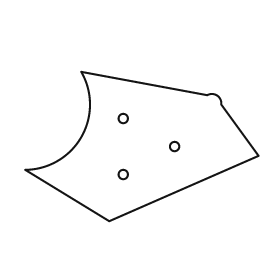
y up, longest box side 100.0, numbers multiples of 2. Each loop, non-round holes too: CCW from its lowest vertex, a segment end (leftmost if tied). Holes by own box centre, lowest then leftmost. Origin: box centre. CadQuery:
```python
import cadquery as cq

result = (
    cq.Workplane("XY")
    .moveTo(-14.0, -32.0)
    .lineTo(50.0, -4.0)
    .lineTo(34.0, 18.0)
    .threePointArc((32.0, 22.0), (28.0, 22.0))
    .lineTo(-26.0, 32.0)
    .threePointArc((-26.0, 4.0), (-50.0, -10.0))
    .close()
    .moveTo(-8.0, -12.0)
    .circle(2.0)
    .moveTo(14.0, 0.0)
    .circle(2.0)
    .moveTo(-8.0, 12.0)
    .circle(2.0)
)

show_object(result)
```